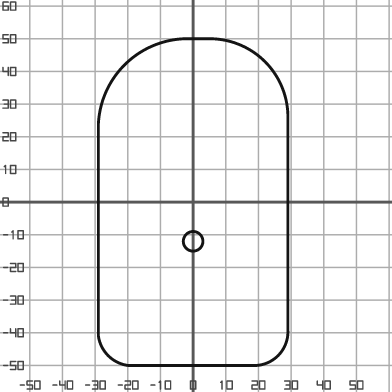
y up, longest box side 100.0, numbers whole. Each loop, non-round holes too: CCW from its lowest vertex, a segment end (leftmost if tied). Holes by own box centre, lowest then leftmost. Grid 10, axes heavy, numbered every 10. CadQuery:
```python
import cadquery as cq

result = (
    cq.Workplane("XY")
    .moveTo(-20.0, -50.0)
    .lineTo(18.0, -50.0)
    .threePointArc((26.0, -47.0), (29.0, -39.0))
    .lineTo(29.0, 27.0)
    .threePointArc((22.0, 43.0), (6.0, 50.0))
    .lineTo(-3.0, 50.0)
    .threePointArc((-21.0, 42.0), (-29.0, 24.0))
    .lineTo(-29.0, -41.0)
    .threePointArc((-26.0, -47.0), (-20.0, -50.0))
    .close()
    .moveTo(0.0, -12.0)
    .circle(3.0)
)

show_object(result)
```